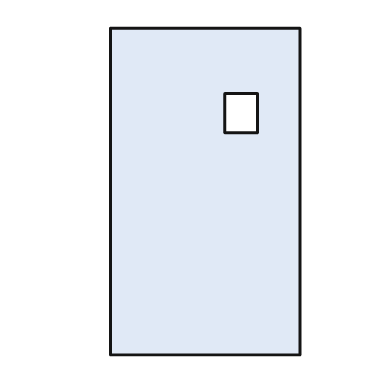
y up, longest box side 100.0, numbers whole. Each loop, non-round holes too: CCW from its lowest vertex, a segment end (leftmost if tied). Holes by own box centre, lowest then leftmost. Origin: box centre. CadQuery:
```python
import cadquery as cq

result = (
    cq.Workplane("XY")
    .moveTo(-29.0, -50.0)
    .lineTo(29.0, -50.0)
    .lineTo(29.0, 50.0)
    .lineTo(-29.0, 50.0)
    .close()
    .moveTo(6.0, 18.0)
    .lineTo(16.0, 18.0)
    .lineTo(16.0, 30.0)
    .lineTo(6.0, 30.0)
    .close()
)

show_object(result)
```